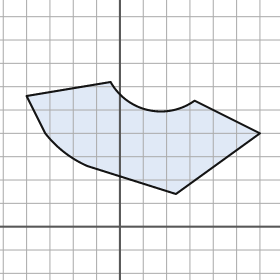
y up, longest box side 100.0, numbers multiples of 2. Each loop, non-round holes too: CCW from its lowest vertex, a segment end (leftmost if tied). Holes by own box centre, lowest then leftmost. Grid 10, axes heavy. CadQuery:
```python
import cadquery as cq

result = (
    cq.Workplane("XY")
    .moveTo(24.0, 14.0)
    .lineTo(60.0, 40.0)
    .lineTo(32.0, 54.0)
    .threePointArc((12.0, 50.0), (-4.0, 62.0))
    .lineTo(-40.0, 56.0)
    .lineTo(-32.0, 40.0)
    .threePointArc((-24.0, 32.0), (-14.0, 26.0))
    .close()
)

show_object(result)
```